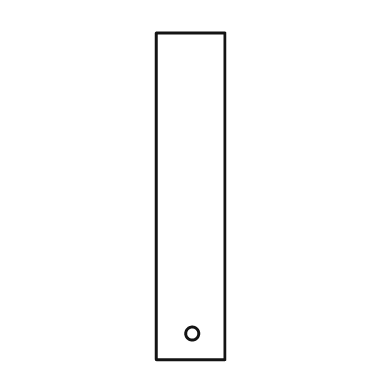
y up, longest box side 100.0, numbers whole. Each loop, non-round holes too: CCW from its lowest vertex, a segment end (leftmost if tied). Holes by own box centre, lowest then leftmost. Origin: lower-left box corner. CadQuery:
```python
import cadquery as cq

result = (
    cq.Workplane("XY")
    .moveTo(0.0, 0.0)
    .lineTo(21.0, 0.0)
    .lineTo(21.0, 100.0)
    .lineTo(0.0, 100.0)
    .close()
    .moveTo(11.0, 8.0)
    .circle(2.0)
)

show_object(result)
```